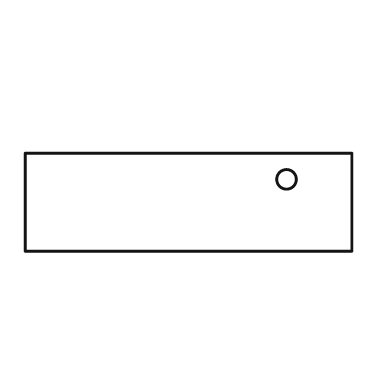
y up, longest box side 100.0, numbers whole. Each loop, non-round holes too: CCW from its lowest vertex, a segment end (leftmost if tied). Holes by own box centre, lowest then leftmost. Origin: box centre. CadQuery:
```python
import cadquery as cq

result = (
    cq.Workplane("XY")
    .moveTo(-50.0, -15.0)
    .lineTo(50.0, -15.0)
    .lineTo(50.0, 15.0)
    .lineTo(-50.0, 15.0)
    .close()
    .moveTo(30.0, 7.0)
    .circle(3.0)
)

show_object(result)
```